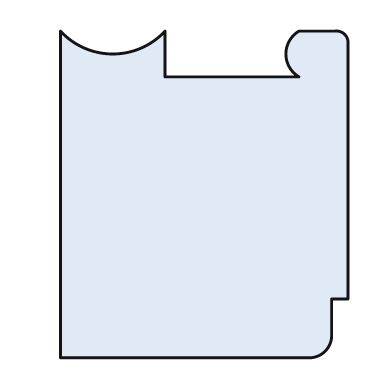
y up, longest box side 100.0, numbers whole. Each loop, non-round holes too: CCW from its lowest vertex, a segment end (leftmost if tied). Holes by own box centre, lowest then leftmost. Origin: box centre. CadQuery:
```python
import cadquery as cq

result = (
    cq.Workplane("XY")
    .moveTo(-44.0, -50.0)
    .lineTo(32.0, -50.0)
    .threePointArc((37.0, -48.0), (39.0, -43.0))
    .lineTo(39.0, -32.0)
    .lineTo(44.0, -32.0)
    .lineTo(44.0, 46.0)
    .threePointArc((43.0, 49.0), (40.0, 50.0))
    .lineTo(29.0, 50.0)
    .threePointArc((25.0, 43.0), (29.0, 36.0))
    .lineTo(-12.0, 36.0)
    .lineTo(-12.0, 50.0)
    .threePointArc((-28.0, 43.0), (-44.0, 50.0))
    .close()
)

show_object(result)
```